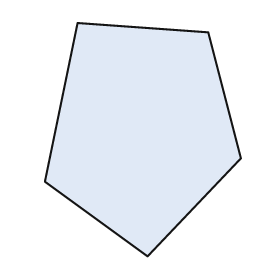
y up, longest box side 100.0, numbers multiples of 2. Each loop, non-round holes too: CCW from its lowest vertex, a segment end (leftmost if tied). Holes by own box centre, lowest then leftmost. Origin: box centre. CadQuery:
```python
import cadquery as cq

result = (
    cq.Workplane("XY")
    .moveTo(2.0, -50.0)
    .lineTo(42.0, -8.0)
    .lineTo(28.0, 46.0)
    .lineTo(-28.0, 50.0)
    .lineTo(-42.0, -18.0)
    .close()
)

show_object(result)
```